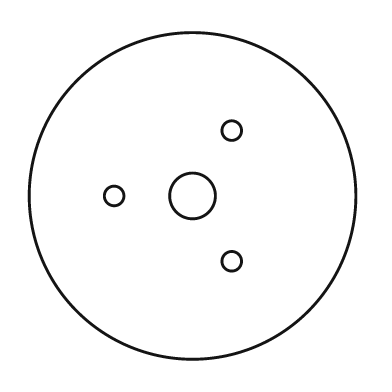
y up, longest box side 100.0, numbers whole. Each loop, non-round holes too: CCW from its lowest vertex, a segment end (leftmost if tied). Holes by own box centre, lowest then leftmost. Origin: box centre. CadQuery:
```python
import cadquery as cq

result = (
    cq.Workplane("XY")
    .moveTo(0.0, 0.0)
    .circle(50.0)
    .moveTo(12.0, -20.0)
    .circle(3.0)
    .moveTo(-24.0, 0.0)
    .circle(3.0)
    .moveTo(0.0, 0.0)
    .circle(7.0)
    .moveTo(12.0, 20.0)
    .circle(3.0)
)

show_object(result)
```